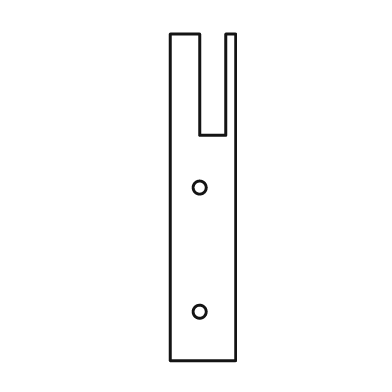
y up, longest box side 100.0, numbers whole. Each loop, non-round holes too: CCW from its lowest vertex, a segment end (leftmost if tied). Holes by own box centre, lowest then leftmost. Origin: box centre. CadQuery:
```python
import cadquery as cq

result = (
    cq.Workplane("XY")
    .moveTo(-10.0, -50.0)
    .lineTo(10.0, -50.0)
    .lineTo(10.0, 50.0)
    .lineTo(7.0, 50.0)
    .lineTo(7.0, 19.0)
    .lineTo(-1.0, 19.0)
    .lineTo(-1.0, 50.0)
    .lineTo(-10.0, 50.0)
    .close()
    .moveTo(-1.0, -35.0)
    .circle(2.0)
    .moveTo(-1.0, 3.0)
    .circle(2.0)
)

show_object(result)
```